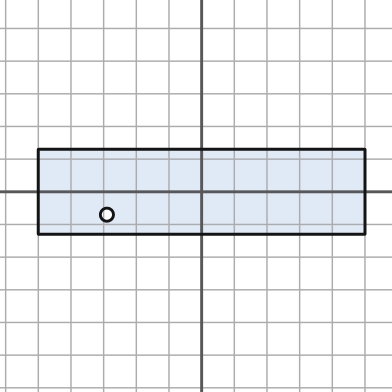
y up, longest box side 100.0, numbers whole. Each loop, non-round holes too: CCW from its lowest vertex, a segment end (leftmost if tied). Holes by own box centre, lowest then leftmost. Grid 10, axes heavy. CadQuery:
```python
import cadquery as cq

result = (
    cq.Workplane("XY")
    .moveTo(-50.0, -13.0)
    .lineTo(50.0, -13.0)
    .lineTo(50.0, 13.0)
    .lineTo(-50.0, 13.0)
    .close()
    .moveTo(-29.0, -7.0)
    .circle(2.0)
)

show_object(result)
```